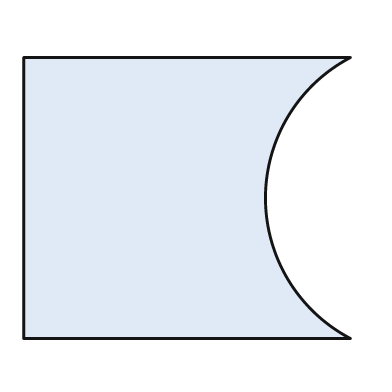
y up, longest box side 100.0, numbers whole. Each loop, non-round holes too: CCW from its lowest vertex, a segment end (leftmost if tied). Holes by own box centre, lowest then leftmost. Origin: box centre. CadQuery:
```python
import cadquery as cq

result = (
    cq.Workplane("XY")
    .moveTo(-50.0, -43.0)
    .lineTo(50.0, -43.0)
    .threePointArc((24.0, 0.0), (50.0, 43.0))
    .lineTo(-50.0, 43.0)
    .close()
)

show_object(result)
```